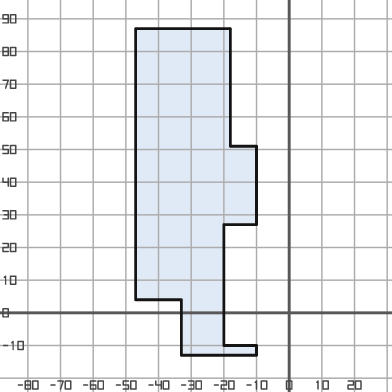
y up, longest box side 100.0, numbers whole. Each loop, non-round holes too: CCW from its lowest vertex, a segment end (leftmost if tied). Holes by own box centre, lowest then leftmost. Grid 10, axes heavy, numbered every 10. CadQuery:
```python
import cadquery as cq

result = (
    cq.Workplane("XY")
    .moveTo(-33.0, -13.0)
    .lineTo(-10.0, -13.0)
    .lineTo(-10.0, -10.0)
    .lineTo(-20.0, -10.0)
    .lineTo(-20.0, 27.0)
    .lineTo(-10.0, 27.0)
    .lineTo(-10.0, 51.0)
    .lineTo(-18.0, 51.0)
    .lineTo(-18.0, 87.0)
    .lineTo(-47.0, 87.0)
    .lineTo(-47.0, 4.0)
    .lineTo(-33.0, 4.0)
    .close()
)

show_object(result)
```